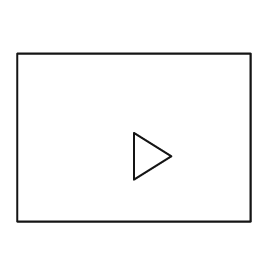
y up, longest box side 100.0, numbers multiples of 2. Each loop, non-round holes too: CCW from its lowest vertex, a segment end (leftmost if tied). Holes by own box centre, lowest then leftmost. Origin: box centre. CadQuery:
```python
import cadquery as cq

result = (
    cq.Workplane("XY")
    .moveTo(-50.0, -36.0)
    .lineTo(50.0, -36.0)
    .lineTo(50.0, 36.0)
    .lineTo(-50.0, 36.0)
    .close()
    .moveTo(0.0, -18.0)
    .lineTo(16.0, -8.0)
    .lineTo(0.0, 2.0)
    .close()
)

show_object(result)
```